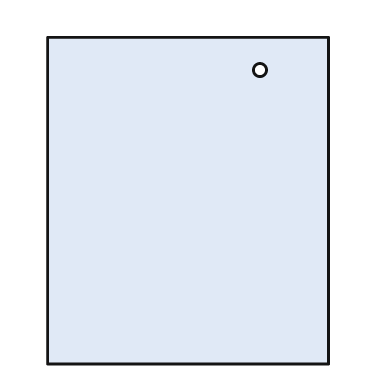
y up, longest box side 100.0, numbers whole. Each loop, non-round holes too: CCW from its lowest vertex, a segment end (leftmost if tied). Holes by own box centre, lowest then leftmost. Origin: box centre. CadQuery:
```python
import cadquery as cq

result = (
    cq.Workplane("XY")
    .moveTo(-43.0, -50.0)
    .lineTo(43.0, -50.0)
    .lineTo(43.0, 50.0)
    .lineTo(-43.0, 50.0)
    .close()
    .moveTo(22.0, 40.0)
    .circle(2.0)
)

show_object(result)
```